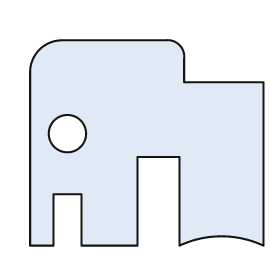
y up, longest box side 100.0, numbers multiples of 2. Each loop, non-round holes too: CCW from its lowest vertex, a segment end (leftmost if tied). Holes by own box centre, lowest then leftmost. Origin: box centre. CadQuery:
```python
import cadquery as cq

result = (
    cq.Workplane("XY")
    .moveTo(-50.0, -44.0)
    .lineTo(-40.0, -44.0)
    .lineTo(-40.0, -22.0)
    .lineTo(-28.0, -22.0)
    .lineTo(-28.0, -44.0)
    .lineTo(-4.0, -44.0)
    .lineTo(-4.0, -6.0)
    .lineTo(14.0, -6.0)
    .lineTo(14.0, -44.0)
    .threePointArc((32.0, -40.0), (50.0, -44.0))
    .lineTo(50.0, 26.0)
    .lineTo(16.0, 26.0)
    .lineTo(16.0, 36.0)
    .threePointArc((14.0, 42.0), (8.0, 44.0))
    .lineTo(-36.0, 44.0)
    .threePointArc((-46.0, 40.0), (-50.0, 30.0))
    .close()
    .moveTo(-34.0, 4.0)
    .circle(8.0)
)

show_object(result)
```